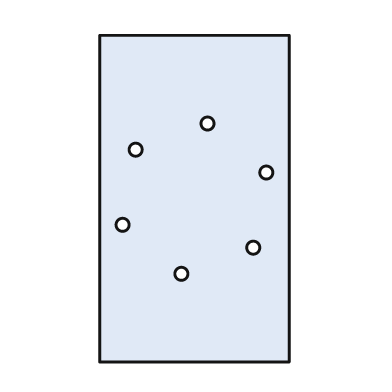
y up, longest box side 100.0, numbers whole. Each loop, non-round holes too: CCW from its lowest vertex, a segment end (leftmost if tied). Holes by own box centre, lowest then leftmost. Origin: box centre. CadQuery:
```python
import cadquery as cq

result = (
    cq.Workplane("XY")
    .moveTo(-29.0, -50.0)
    .lineTo(29.0, -50.0)
    .lineTo(29.0, 50.0)
    .lineTo(-29.0, 50.0)
    .close()
    .moveTo(-4.0, -23.0)
    .circle(2.0)
    .moveTo(18.0, -15.0)
    .circle(2.0)
    .moveTo(-22.0, -8.0)
    .circle(2.0)
    .moveTo(22.0, 8.0)
    .circle(2.0)
    .moveTo(-18.0, 15.0)
    .circle(2.0)
    .moveTo(4.0, 23.0)
    .circle(2.0)
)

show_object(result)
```